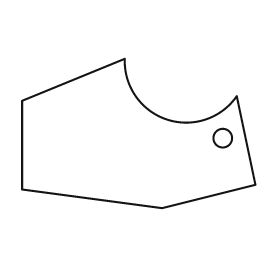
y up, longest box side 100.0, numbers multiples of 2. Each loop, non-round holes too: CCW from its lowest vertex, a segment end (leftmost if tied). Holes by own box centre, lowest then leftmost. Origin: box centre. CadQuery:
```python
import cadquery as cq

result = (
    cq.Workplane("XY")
    .moveTo(10.0, -32.0)
    .lineTo(50.0, -22.0)
    .lineTo(42.0, 16.0)
    .threePointArc((12.0, 6.0), (-6.0, 32.0))
    .lineTo(-50.0, 14.0)
    .lineTo(-50.0, -24.0)
    .close()
    .moveTo(36.0, -2.0)
    .circle(4.0)
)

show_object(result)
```